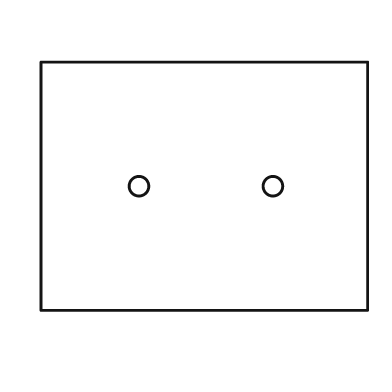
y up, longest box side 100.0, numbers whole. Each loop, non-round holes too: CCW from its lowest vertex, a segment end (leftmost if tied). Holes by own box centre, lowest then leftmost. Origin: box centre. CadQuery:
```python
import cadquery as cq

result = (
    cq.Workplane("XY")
    .moveTo(-50.0, -38.0)
    .lineTo(50.0, -38.0)
    .lineTo(50.0, 38.0)
    .lineTo(-50.0, 38.0)
    .close()
    .moveTo(-20.0, 0.0)
    .circle(3.0)
    .moveTo(21.0, 0.0)
    .circle(3.0)
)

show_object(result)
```